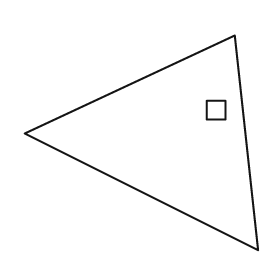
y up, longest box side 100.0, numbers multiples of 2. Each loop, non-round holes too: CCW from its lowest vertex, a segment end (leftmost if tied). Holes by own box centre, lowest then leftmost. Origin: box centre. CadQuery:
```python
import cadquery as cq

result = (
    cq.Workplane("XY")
    .moveTo(50.0, -46.0)
    .lineTo(40.0, 46.0)
    .lineTo(-50.0, 4.0)
    .close()
    .moveTo(28.0, 10.0)
    .lineTo(36.0, 10.0)
    .lineTo(36.0, 18.0)
    .lineTo(28.0, 18.0)
    .close()
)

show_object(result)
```